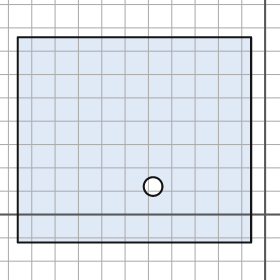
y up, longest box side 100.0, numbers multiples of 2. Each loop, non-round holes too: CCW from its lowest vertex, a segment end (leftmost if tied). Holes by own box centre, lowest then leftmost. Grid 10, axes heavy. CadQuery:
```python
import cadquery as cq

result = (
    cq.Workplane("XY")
    .moveTo(-106.0, -12.0)
    .lineTo(-6.0, -12.0)
    .lineTo(-6.0, 76.0)
    .lineTo(-106.0, 76.0)
    .close()
    .moveTo(-48.0, 12.0)
    .circle(4.0)
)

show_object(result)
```